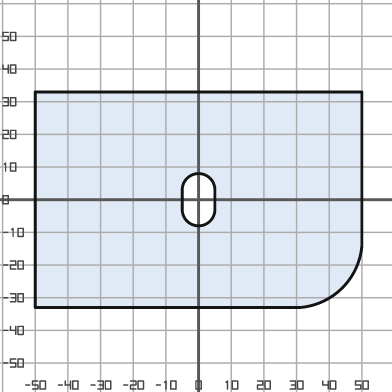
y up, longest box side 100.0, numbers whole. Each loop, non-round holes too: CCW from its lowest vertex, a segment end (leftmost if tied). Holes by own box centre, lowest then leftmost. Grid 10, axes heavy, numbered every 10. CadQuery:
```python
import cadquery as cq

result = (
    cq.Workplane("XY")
    .moveTo(-50.0, -33.0)
    .lineTo(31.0, -33.0)
    .threePointArc((44.0, -27.0), (50.0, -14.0))
    .lineTo(50.0, 33.0)
    .lineTo(-50.0, 33.0)
    .close()
    .moveTo(-5.0, -3.0)
    .threePointArc((0.0, -8.0), (5.0, -3.0))
    .lineTo(5.0, 3.0)
    .threePointArc((0.0, 8.0), (-5.0, 3.0))
    .close()
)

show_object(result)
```